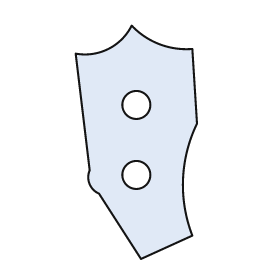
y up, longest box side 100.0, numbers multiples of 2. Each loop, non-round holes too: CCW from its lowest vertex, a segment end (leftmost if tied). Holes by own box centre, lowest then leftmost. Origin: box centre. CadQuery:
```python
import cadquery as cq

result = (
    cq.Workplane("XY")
    .moveTo(2.0, -50.0)
    .lineTo(24.0, -40.0)
    .threePointArc((20.0, -16.0), (26.0, 8.0))
    .lineTo(24.0, 40.0)
    .threePointArc((10.0, 42.0), (-2.0, 50.0))
    .threePointArc((-12.0, 40.0), (-26.0, 38.0))
    .lineTo(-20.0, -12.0)
    .threePointArc((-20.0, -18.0), (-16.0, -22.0))
    .close()
    .moveTo(0.0, -14.0)
    .circle(6.0)
    .moveTo(0.0, 16.0)
    .circle(6.0)
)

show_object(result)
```